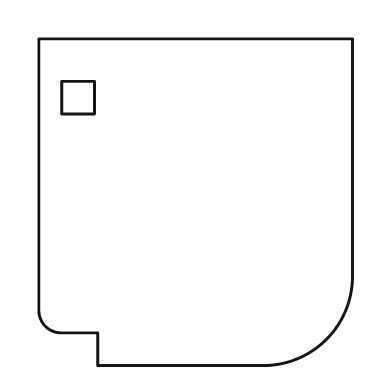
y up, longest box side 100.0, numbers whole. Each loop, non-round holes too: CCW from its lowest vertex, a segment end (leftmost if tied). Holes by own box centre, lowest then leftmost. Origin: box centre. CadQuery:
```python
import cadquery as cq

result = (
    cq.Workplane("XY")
    .moveTo(-30.0, -50.0)
    .lineTo(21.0, -50.0)
    .threePointArc((40.0, -42.0), (48.0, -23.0))
    .lineTo(48.0, 50.0)
    .lineTo(-48.0, 50.0)
    .lineTo(-48.0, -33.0)
    .threePointArc((-46.0, -38.0), (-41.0, -40.0))
    .lineTo(-30.0, -40.0)
    .close()
    .moveTo(-41.0, 27.0)
    .lineTo(-31.0, 27.0)
    .lineTo(-31.0, 37.0)
    .lineTo(-41.0, 37.0)
    .close()
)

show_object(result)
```